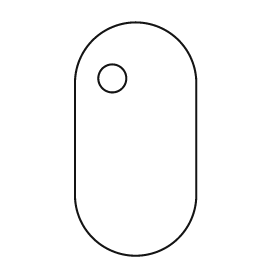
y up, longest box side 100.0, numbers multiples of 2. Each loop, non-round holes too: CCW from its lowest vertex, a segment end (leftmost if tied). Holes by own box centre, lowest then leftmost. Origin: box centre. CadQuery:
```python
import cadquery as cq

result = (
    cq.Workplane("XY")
    .moveTo(-26.0, -24.0)
    .threePointArc((0.0, -50.0), (26.0, -24.0))
    .lineTo(26.0, 24.0)
    .threePointArc((0.0, 50.0), (-26.0, 24.0))
    .close()
    .moveTo(-10.0, 26.0)
    .circle(6.0)
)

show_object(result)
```